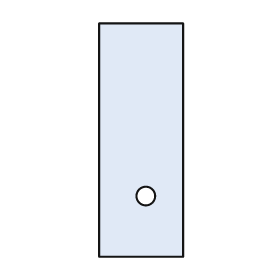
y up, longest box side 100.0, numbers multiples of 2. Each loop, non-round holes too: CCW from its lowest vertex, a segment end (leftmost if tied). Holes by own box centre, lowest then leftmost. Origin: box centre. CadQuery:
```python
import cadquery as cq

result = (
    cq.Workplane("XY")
    .moveTo(-18.0, -50.0)
    .lineTo(18.0, -50.0)
    .lineTo(18.0, 50.0)
    .lineTo(-18.0, 50.0)
    .close()
    .moveTo(2.0, -24.0)
    .circle(4.0)
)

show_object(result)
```